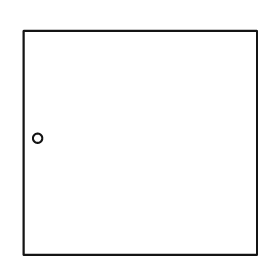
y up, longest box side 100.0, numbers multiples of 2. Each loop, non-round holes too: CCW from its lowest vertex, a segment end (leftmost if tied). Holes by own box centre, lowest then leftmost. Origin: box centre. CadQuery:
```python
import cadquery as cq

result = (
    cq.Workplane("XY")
    .moveTo(-50.0, -48.0)
    .lineTo(50.0, -48.0)
    .lineTo(50.0, 48.0)
    .lineTo(-50.0, 48.0)
    .close()
    .moveTo(-44.0, 2.0)
    .circle(2.0)
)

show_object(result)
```